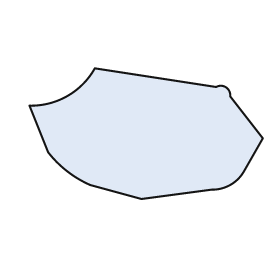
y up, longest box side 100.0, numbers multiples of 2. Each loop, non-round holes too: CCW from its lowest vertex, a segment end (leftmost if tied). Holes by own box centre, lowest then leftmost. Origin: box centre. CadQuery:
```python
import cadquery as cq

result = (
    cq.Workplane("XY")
    .moveTo(-2.0, -28.0)
    .lineTo(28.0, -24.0)
    .threePointArc((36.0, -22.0), (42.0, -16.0))
    .lineTo(50.0, -2.0)
    .lineTo(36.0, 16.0)
    .threePointArc((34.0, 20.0), (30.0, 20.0))
    .lineTo(-22.0, 28.0)
    .threePointArc((-34.0, 16.0), (-50.0, 12.0))
    .lineTo(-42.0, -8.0)
    .threePointArc((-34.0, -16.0), (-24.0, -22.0))
    .close()
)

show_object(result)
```